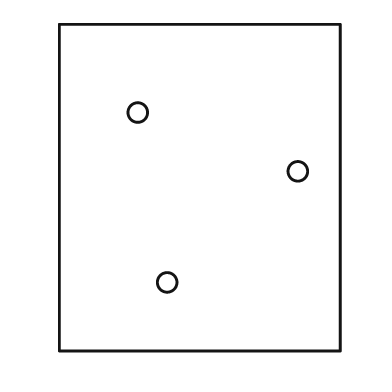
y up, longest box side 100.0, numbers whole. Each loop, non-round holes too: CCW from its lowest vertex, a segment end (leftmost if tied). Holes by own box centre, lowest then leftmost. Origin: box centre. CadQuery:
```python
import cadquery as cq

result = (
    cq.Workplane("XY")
    .moveTo(-43.0, -50.0)
    .lineTo(43.0, -50.0)
    .lineTo(43.0, 50.0)
    .lineTo(-43.0, 50.0)
    .close()
    .moveTo(-10.0, -29.0)
    .circle(3.0)
    .moveTo(30.0, 5.0)
    .circle(3.0)
    .moveTo(-19.0, 23.0)
    .circle(3.0)
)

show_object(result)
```